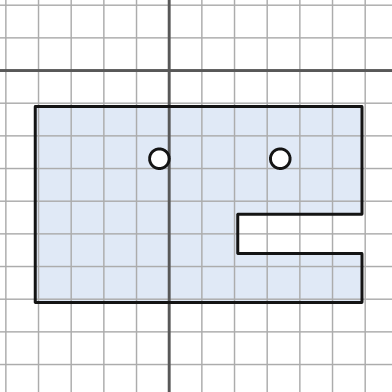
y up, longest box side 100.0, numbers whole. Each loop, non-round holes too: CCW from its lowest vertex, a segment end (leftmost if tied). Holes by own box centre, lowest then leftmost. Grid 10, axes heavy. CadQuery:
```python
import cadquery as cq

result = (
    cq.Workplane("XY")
    .moveTo(-41.0, -71.0)
    .lineTo(59.0, -71.0)
    .lineTo(59.0, -56.0)
    .lineTo(21.0, -56.0)
    .lineTo(21.0, -44.0)
    .lineTo(59.0, -44.0)
    .lineTo(59.0, -11.0)
    .lineTo(-41.0, -11.0)
    .close()
    .moveTo(-3.0, -27.0)
    .circle(3.0)
    .moveTo(34.0, -27.0)
    .circle(3.0)
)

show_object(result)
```